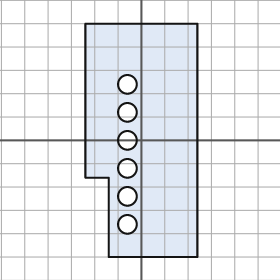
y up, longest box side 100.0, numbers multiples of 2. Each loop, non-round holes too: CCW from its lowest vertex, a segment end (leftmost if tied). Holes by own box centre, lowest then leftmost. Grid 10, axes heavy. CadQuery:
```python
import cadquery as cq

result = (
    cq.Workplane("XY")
    .moveTo(-14.0, -50.0)
    .lineTo(24.0, -50.0)
    .lineTo(24.0, 50.0)
    .lineTo(-24.0, 50.0)
    .lineTo(-24.0, -16.0)
    .lineTo(-14.0, -16.0)
    .close()
    .moveTo(-6.0, -36.0)
    .circle(4.0)
    .moveTo(-6.0, -24.0)
    .circle(4.0)
    .moveTo(-6.0, -12.0)
    .circle(4.0)
    .moveTo(-6.0, 0.0)
    .circle(4.0)
    .moveTo(-6.0, 12.0)
    .circle(4.0)
    .moveTo(-6.0, 24.0)
    .circle(4.0)
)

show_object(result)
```